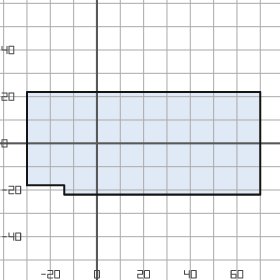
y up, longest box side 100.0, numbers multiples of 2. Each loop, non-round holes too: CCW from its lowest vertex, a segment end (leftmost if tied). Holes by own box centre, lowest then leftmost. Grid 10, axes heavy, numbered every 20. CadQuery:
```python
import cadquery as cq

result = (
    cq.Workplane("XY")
    .moveTo(-14.0, -22.0)
    .lineTo(70.0, -22.0)
    .lineTo(70.0, 22.0)
    .lineTo(-30.0, 22.0)
    .lineTo(-30.0, -18.0)
    .lineTo(-14.0, -18.0)
    .close()
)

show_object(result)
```